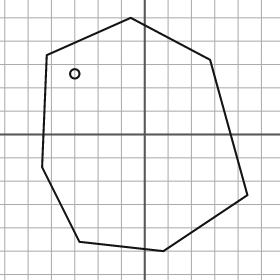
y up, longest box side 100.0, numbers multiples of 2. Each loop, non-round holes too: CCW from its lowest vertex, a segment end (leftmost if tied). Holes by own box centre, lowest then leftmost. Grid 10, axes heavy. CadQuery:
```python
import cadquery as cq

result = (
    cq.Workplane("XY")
    .moveTo(8.0, -50.0)
    .lineTo(44.0, -26.0)
    .lineTo(28.0, 32.0)
    .lineTo(-6.0, 50.0)
    .lineTo(-42.0, 34.0)
    .lineTo(-44.0, -14.0)
    .lineTo(-28.0, -46.0)
    .close()
    .moveTo(-30.0, 26.0)
    .circle(2.0)
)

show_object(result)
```